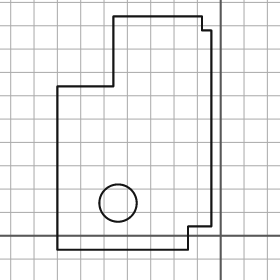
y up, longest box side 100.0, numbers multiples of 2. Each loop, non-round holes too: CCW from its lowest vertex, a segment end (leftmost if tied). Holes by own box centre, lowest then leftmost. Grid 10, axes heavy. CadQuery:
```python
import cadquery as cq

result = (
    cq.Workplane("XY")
    .moveTo(-70.0, -6.0)
    .lineTo(-14.0, -6.0)
    .lineTo(-14.0, 4.0)
    .lineTo(-4.0, 4.0)
    .lineTo(-4.0, 88.0)
    .lineTo(-8.0, 88.0)
    .lineTo(-8.0, 94.0)
    .lineTo(-46.0, 94.0)
    .lineTo(-46.0, 64.0)
    .lineTo(-70.0, 64.0)
    .close()
    .moveTo(-44.0, 14.0)
    .circle(8.0)
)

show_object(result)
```